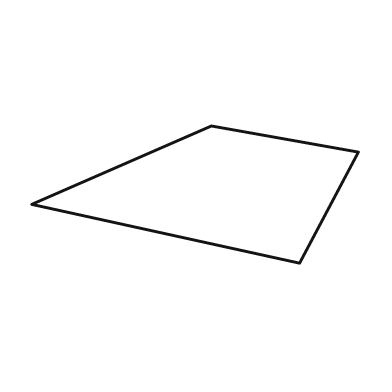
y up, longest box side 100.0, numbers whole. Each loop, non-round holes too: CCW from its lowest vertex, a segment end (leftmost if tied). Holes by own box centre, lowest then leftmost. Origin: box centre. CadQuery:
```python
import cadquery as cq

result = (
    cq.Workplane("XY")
    .moveTo(32.0, -21.0)
    .lineTo(50.0, 13.0)
    .lineTo(5.0, 21.0)
    .lineTo(-50.0, -3.0)
    .close()
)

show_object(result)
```